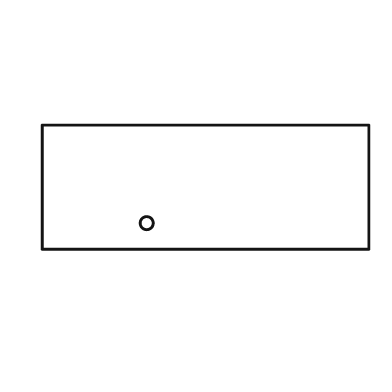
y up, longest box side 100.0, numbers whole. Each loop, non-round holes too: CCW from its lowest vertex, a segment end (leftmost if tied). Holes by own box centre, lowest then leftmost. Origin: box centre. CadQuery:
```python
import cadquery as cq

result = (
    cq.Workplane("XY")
    .moveTo(-50.0, -19.0)
    .lineTo(50.0, -19.0)
    .lineTo(50.0, 19.0)
    .lineTo(-50.0, 19.0)
    .close()
    .moveTo(-18.0, -11.0)
    .circle(2.0)
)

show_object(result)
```